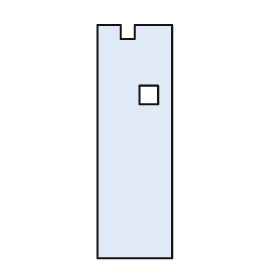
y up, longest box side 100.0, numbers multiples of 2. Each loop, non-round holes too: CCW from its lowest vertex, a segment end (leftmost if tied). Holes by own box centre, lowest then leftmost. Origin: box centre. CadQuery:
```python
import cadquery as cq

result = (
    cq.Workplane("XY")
    .moveTo(-16.0, -50.0)
    .lineTo(16.0, -50.0)
    .lineTo(16.0, 50.0)
    .lineTo(0.0, 50.0)
    .lineTo(0.0, 44.0)
    .lineTo(-6.0, 44.0)
    .lineTo(-6.0, 50.0)
    .lineTo(-16.0, 50.0)
    .close()
    .moveTo(2.0, 16.0)
    .lineTo(10.0, 16.0)
    .lineTo(10.0, 24.0)
    .lineTo(2.0, 24.0)
    .close()
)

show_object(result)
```